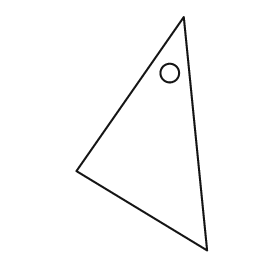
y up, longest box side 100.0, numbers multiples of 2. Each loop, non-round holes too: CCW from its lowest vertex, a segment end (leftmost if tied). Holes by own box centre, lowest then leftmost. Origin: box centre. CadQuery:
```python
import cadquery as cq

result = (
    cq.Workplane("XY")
    .moveTo(28.0, -50.0)
    .lineTo(18.0, 50.0)
    .lineTo(-28.0, -16.0)
    .close()
    .moveTo(12.0, 26.0)
    .circle(4.0)
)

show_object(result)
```